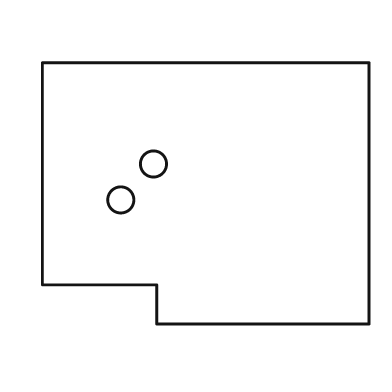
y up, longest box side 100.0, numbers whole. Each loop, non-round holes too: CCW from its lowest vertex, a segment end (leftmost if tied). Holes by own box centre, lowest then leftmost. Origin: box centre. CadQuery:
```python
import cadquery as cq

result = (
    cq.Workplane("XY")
    .moveTo(-15.0, -40.0)
    .lineTo(50.0, -40.0)
    .lineTo(50.0, 40.0)
    .lineTo(-50.0, 40.0)
    .lineTo(-50.0, -28.0)
    .lineTo(-15.0, -28.0)
    .close()
    .moveTo(-26.0, -2.0)
    .circle(4.0)
    .moveTo(-16.0, 9.0)
    .circle(4.0)
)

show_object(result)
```